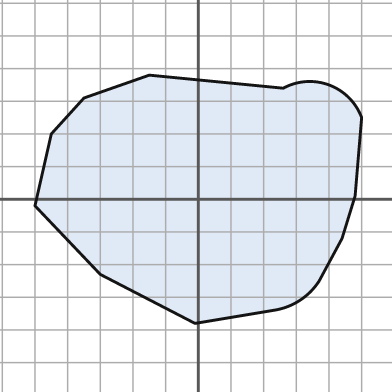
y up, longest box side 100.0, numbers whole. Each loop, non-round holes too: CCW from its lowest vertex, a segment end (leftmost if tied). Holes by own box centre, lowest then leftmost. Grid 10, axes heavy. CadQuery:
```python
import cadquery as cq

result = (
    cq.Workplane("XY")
    .moveTo(-1.0, -38.0)
    .lineTo(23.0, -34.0)
    .threePointArc((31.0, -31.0), (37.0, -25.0))
    .lineTo(44.0, -12.0)
    .lineTo(48.0, 1.0)
    .lineTo(50.0, 25.0)
    .threePointArc((40.0, 35.0), (26.0, 34.0))
    .lineTo(-15.0, 38.0)
    .lineTo(-35.0, 31.0)
    .lineTo(-45.0, 20.0)
    .lineTo(-50.0, -2.0)
    .lineTo(-30.0, -23.0)
    .close()
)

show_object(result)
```